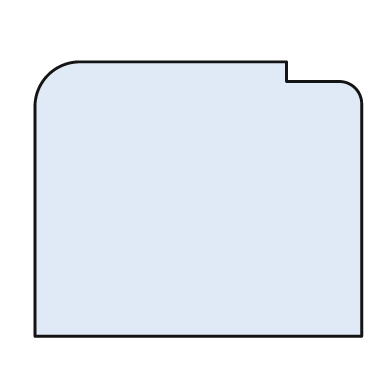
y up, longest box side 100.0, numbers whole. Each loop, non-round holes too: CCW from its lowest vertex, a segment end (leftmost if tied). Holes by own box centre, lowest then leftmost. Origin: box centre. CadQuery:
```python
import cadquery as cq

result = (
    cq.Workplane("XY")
    .moveTo(-50.0, -42.0)
    .lineTo(50.0, -42.0)
    .lineTo(50.0, 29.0)
    .threePointArc((48.0, 34.0), (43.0, 36.0))
    .lineTo(27.0, 36.0)
    .lineTo(27.0, 42.0)
    .lineTo(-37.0, 42.0)
    .threePointArc((-46.0, 38.0), (-50.0, 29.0))
    .close()
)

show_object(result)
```